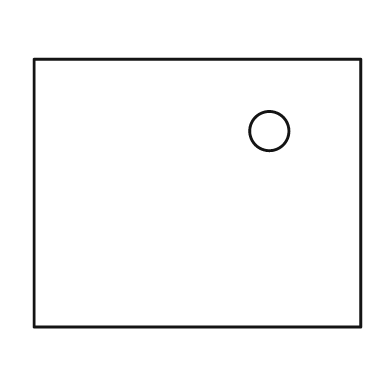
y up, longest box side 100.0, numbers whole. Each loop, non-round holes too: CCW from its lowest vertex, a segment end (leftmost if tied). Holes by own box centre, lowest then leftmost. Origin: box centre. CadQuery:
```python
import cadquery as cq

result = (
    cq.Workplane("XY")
    .moveTo(-50.0, -41.0)
    .lineTo(50.0, -41.0)
    .lineTo(50.0, 41.0)
    .lineTo(-50.0, 41.0)
    .close()
    .moveTo(22.0, 19.0)
    .circle(6.0)
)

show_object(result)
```